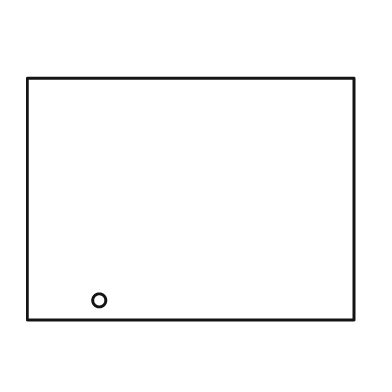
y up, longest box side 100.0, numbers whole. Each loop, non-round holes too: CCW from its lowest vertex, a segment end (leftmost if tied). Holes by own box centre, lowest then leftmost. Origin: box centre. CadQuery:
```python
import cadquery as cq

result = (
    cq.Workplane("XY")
    .moveTo(-50.0, -37.0)
    .lineTo(50.0, -37.0)
    .lineTo(50.0, 37.0)
    .lineTo(-50.0, 37.0)
    .close()
    .moveTo(-28.0, -31.0)
    .circle(2.0)
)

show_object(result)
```